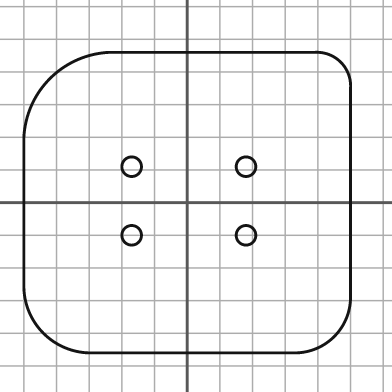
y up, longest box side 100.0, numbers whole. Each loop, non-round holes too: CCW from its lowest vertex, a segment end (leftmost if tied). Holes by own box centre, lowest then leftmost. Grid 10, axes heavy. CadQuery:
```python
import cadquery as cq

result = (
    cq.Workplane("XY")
    .moveTo(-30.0, -46.0)
    .lineTo(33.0, -46.0)
    .threePointArc((45.0, -41.0), (50.0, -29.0))
    .lineTo(50.0, 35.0)
    .threePointArc((47.0, 43.0), (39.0, 46.0))
    .lineTo(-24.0, 46.0)
    .threePointArc((-42.0, 38.0), (-50.0, 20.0))
    .lineTo(-50.0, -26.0)
    .threePointArc((-44.0, -40.0), (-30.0, -46.0))
    .close()
    .moveTo(-17.0, -10.0)
    .circle(3.0)
    .moveTo(18.0, -10.0)
    .circle(3.0)
    .moveTo(-17.0, 11.0)
    .circle(3.0)
    .moveTo(18.0, 11.0)
    .circle(3.0)
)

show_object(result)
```